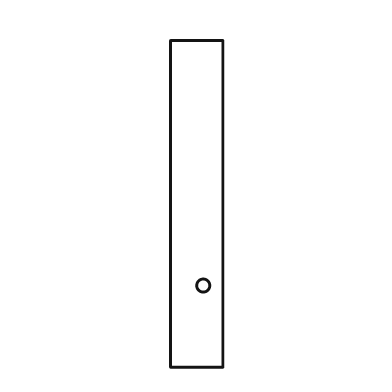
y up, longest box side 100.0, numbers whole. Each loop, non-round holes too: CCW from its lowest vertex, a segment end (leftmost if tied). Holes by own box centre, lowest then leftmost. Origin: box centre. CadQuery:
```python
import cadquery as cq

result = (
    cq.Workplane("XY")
    .moveTo(-8.0, -50.0)
    .lineTo(8.0, -50.0)
    .lineTo(8.0, 50.0)
    .lineTo(-8.0, 50.0)
    .close()
    .moveTo(2.0, -25.0)
    .circle(2.0)
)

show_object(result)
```